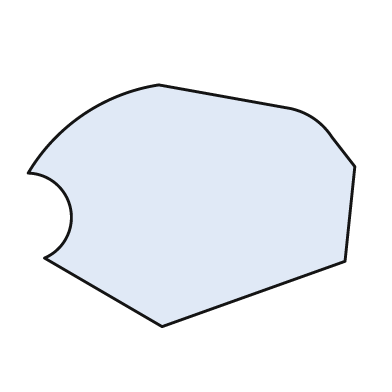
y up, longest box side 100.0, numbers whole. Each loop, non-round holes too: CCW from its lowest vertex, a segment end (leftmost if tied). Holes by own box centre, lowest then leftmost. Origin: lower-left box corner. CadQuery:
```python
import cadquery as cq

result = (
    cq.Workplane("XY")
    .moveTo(41.0, 0.0)
    .lineTo(97.0, 20.0)
    .lineTo(100.0, 49.0)
    .lineTo(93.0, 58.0)
    .threePointArc((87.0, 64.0), (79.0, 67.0))
    .lineTo(40.0, 74.0)
    .threePointArc((17.0, 65.0), (0.0, 47.0))
    .threePointArc((13.0, 36.0), (5.0, 21.0))
    .close()
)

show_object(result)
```